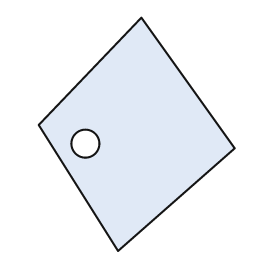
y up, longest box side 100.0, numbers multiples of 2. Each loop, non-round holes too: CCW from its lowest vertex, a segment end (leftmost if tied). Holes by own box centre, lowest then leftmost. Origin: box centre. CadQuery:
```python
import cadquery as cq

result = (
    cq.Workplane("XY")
    .moveTo(-8.0, -50.0)
    .lineTo(42.0, -6.0)
    .lineTo(2.0, 50.0)
    .lineTo(-42.0, 4.0)
    .close()
    .moveTo(-22.0, -4.0)
    .circle(6.0)
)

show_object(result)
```